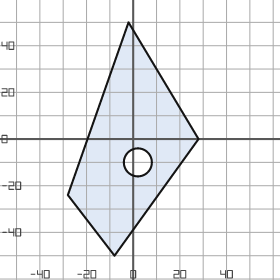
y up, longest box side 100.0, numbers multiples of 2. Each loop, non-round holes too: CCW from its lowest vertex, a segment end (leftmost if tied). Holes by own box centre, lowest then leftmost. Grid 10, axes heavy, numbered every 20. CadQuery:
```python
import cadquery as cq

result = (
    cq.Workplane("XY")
    .moveTo(-8.0, -50.0)
    .lineTo(28.0, 0.0)
    .lineTo(-2.0, 50.0)
    .lineTo(-28.0, -24.0)
    .close()
    .moveTo(2.0, -10.0)
    .circle(6.0)
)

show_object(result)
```